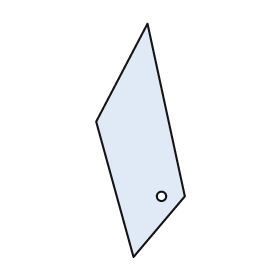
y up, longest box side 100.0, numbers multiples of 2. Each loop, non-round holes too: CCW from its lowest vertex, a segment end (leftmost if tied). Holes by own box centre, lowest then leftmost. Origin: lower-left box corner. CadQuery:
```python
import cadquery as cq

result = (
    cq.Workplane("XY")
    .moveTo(16.0, 0.0)
    .lineTo(38.0, 26.0)
    .lineTo(22.0, 100.0)
    .lineTo(0.0, 58.0)
    .close()
    .moveTo(28.0, 26.0)
    .circle(2.0)
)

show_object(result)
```